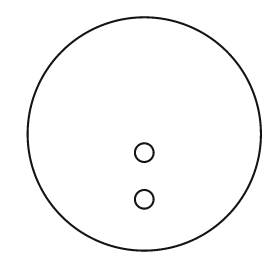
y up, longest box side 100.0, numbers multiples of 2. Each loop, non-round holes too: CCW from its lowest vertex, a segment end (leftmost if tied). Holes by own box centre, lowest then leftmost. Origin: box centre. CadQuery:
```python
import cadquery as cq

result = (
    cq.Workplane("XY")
    .moveTo(0.0, 0.0)
    .circle(50.0)
    .moveTo(0.0, -28.0)
    .circle(4.0)
    .moveTo(0.0, -8.0)
    .circle(4.0)
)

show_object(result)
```